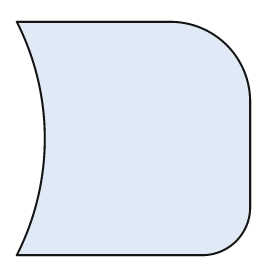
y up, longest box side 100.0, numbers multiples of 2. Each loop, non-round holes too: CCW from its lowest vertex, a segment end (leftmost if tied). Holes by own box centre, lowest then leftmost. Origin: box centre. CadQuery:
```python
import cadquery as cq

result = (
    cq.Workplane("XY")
    .moveTo(-50.0, -50.0)
    .lineTo(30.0, -50.0)
    .threePointArc((44.0, -44.0), (50.0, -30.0))
    .lineTo(50.0, 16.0)
    .threePointArc((40.0, 40.0), (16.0, 50.0))
    .lineTo(-50.0, 50.0)
    .threePointArc((-38.0, 0.0), (-50.0, -50.0))
    .close()
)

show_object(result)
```